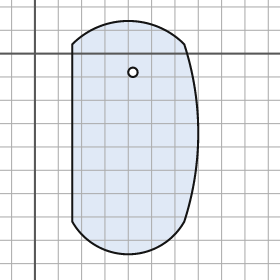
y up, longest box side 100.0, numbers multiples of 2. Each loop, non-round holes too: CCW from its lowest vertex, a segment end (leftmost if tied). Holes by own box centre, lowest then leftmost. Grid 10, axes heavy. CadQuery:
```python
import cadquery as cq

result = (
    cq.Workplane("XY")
    .moveTo(16.0, -72.0)
    .threePointArc((40.0, -86.0), (64.0, -72.0))
    .threePointArc((70.0, -34.0), (64.0, 4.0))
    .threePointArc((40.0, 14.0), (16.0, 4.0))
    .close()
    .moveTo(42.0, -8.0)
    .circle(2.0)
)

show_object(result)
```